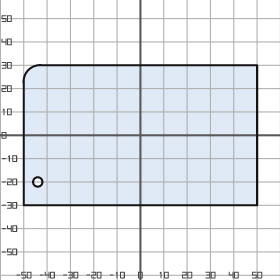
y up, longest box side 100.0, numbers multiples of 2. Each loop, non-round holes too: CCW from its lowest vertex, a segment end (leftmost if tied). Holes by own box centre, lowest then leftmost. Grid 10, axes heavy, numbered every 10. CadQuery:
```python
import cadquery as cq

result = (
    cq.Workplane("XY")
    .moveTo(-50.0, -30.0)
    .lineTo(50.0, -30.0)
    .lineTo(50.0, 30.0)
    .lineTo(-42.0, 30.0)
    .threePointArc((-48.0, 28.0), (-50.0, 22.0))
    .close()
    .moveTo(-44.0, -20.0)
    .circle(2.0)
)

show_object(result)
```